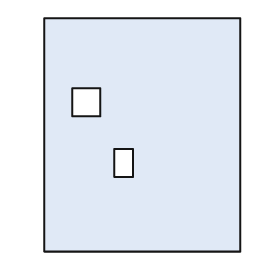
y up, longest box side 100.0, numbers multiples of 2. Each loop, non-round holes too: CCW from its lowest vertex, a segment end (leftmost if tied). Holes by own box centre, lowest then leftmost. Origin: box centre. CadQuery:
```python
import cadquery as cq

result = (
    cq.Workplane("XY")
    .moveTo(-42.0, -50.0)
    .lineTo(42.0, -50.0)
    .lineTo(42.0, 50.0)
    .lineTo(-42.0, 50.0)
    .close()
    .moveTo(-12.0, -18.0)
    .lineTo(-4.0, -18.0)
    .lineTo(-4.0, -6.0)
    .lineTo(-12.0, -6.0)
    .close()
    .moveTo(-30.0, 8.0)
    .lineTo(-18.0, 8.0)
    .lineTo(-18.0, 20.0)
    .lineTo(-30.0, 20.0)
    .close()
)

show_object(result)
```